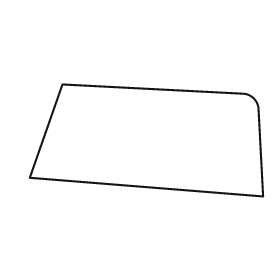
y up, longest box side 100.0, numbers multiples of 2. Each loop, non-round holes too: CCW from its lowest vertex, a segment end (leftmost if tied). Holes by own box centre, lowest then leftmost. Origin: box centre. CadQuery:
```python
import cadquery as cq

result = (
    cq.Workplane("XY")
    .moveTo(50.0, -24.0)
    .lineTo(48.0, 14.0)
    .threePointArc((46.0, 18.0), (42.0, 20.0))
    .lineTo(-36.0, 24.0)
    .lineTo(-50.0, -16.0)
    .close()
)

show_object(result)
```